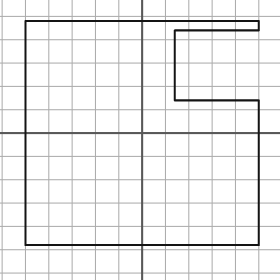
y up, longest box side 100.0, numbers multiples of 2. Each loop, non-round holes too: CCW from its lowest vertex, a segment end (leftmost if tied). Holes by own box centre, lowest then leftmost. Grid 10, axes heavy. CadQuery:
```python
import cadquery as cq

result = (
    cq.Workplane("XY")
    .moveTo(-50.0, -48.0)
    .lineTo(50.0, -48.0)
    .lineTo(50.0, 14.0)
    .lineTo(14.0, 14.0)
    .lineTo(14.0, 44.0)
    .lineTo(50.0, 44.0)
    .lineTo(50.0, 48.0)
    .lineTo(-50.0, 48.0)
    .close()
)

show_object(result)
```